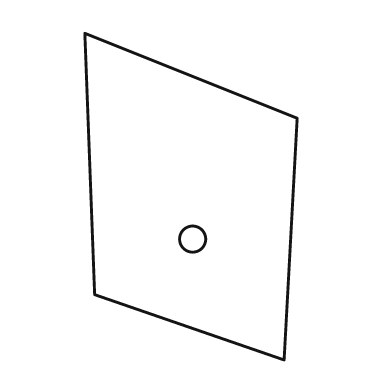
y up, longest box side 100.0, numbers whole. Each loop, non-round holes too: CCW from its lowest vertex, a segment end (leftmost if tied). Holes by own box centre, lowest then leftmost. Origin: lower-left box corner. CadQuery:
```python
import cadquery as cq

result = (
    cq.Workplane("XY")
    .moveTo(61.0, 0.0)
    .lineTo(65.0, 74.0)
    .lineTo(0.0, 100.0)
    .lineTo(3.0, 20.0)
    .close()
    .moveTo(33.0, 37.0)
    .circle(4.0)
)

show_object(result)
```